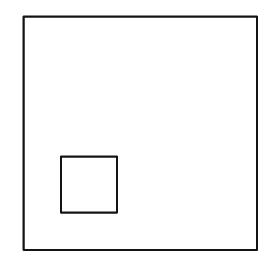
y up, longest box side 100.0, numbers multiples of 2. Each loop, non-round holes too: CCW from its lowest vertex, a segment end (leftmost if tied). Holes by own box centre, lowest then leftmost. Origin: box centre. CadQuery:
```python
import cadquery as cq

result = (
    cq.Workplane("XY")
    .moveTo(-50.0, -50.0)
    .lineTo(50.0, -50.0)
    .lineTo(50.0, 50.0)
    .lineTo(-50.0, 50.0)
    .close()
    .moveTo(-34.0, -34.0)
    .lineTo(-10.0, -34.0)
    .lineTo(-10.0, -10.0)
    .lineTo(-34.0, -10.0)
    .close()
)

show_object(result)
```